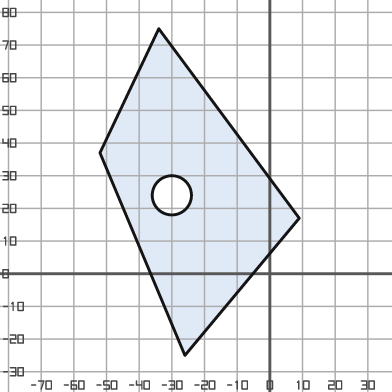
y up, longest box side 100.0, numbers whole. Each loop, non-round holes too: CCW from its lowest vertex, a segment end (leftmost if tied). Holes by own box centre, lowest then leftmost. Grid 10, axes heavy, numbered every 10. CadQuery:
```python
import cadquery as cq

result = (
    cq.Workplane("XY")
    .moveTo(-26.0, -25.0)
    .lineTo(9.0, 17.0)
    .lineTo(-34.0, 75.0)
    .lineTo(-52.0, 37.0)
    .close()
    .moveTo(-30.0, 24.0)
    .circle(6.0)
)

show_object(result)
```